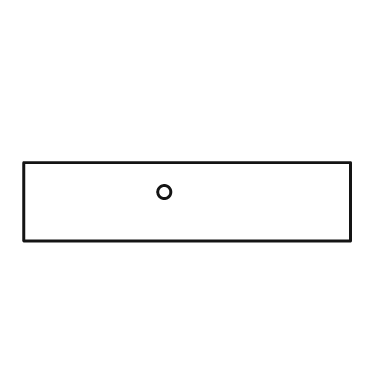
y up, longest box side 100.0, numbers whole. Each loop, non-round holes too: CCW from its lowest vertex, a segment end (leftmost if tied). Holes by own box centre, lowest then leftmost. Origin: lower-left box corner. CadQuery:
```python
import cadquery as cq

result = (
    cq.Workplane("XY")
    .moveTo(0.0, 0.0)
    .lineTo(100.0, 0.0)
    .lineTo(100.0, 24.0)
    .lineTo(0.0, 24.0)
    .close()
    .moveTo(43.0, 15.0)
    .circle(2.0)
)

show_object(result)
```